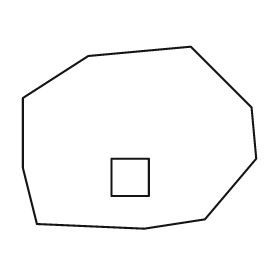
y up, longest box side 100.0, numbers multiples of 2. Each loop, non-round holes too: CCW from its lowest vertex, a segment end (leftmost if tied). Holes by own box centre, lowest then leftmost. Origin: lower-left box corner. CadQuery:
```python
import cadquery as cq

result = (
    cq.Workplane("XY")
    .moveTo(52.0, 0.0)
    .lineTo(78.0, 4.0)
    .lineTo(100.0, 30.0)
    .lineTo(98.0, 52.0)
    .lineTo(72.0, 78.0)
    .lineTo(28.0, 74.0)
    .lineTo(0.0, 56.0)
    .lineTo(0.0, 26.0)
    .lineTo(6.0, 2.0)
    .close()
    .moveTo(38.0, 14.0)
    .lineTo(54.0, 14.0)
    .lineTo(54.0, 30.0)
    .lineTo(38.0, 30.0)
    .close()
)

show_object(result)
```